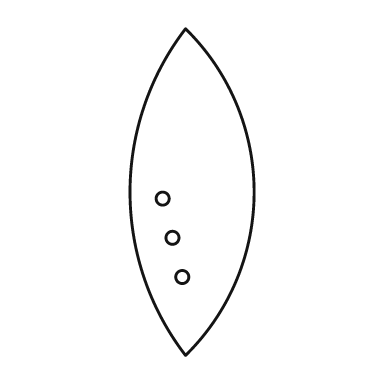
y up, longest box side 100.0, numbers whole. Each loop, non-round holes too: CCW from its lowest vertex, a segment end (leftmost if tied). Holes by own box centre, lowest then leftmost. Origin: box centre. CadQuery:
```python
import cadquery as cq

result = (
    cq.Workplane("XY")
    .moveTo(-2.0, -50.0)
    .threePointArc((19.0, 0.0), (-2.0, 50.0))
    .threePointArc((-19.0, 0.0), (-2.0, -50.0))
    .close()
    .moveTo(-3.0, -26.0)
    .circle(2.0)
    .moveTo(-6.0, -14.0)
    .circle(2.0)
    .moveTo(-9.0, -2.0)
    .circle(2.0)
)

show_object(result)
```